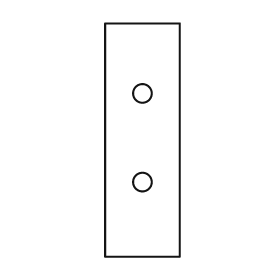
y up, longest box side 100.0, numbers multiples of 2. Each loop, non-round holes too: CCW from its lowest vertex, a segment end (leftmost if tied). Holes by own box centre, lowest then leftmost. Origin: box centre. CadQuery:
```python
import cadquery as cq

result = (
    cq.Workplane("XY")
    .moveTo(-16.0, -50.0)
    .lineTo(16.0, -50.0)
    .lineTo(16.0, 50.0)
    .lineTo(-16.0, 50.0)
    .close()
    .moveTo(0.0, -18.0)
    .circle(4.0)
    .moveTo(0.0, 20.0)
    .circle(4.0)
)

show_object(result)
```